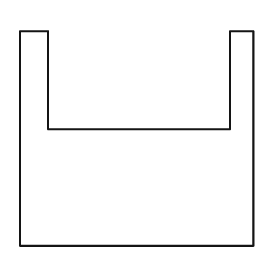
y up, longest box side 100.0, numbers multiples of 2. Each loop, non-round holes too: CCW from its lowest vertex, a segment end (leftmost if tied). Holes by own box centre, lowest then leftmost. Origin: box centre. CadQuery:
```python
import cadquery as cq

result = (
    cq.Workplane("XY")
    .moveTo(-50.0, -46.0)
    .lineTo(50.0, -46.0)
    .lineTo(50.0, 46.0)
    .lineTo(40.0, 46.0)
    .lineTo(40.0, 4.0)
    .lineTo(-38.0, 4.0)
    .lineTo(-38.0, 46.0)
    .lineTo(-50.0, 46.0)
    .close()
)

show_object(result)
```